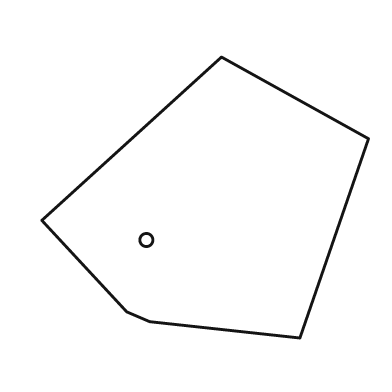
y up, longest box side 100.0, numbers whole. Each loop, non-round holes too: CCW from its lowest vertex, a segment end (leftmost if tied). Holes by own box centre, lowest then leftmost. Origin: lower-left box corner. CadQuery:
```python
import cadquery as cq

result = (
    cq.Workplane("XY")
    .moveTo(79.0, 0.0)
    .lineTo(100.0, 61.0)
    .lineTo(55.0, 86.0)
    .lineTo(0.0, 36.0)
    .lineTo(26.0, 8.0)
    .lineTo(33.0, 5.0)
    .close()
    .moveTo(32.0, 30.0)
    .circle(2.0)
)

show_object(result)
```